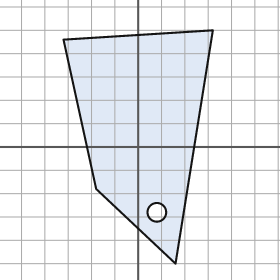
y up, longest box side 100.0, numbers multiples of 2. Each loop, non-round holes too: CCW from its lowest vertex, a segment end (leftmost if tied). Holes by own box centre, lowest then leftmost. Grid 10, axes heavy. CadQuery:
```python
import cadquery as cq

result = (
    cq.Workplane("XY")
    .moveTo(16.0, -50.0)
    .lineTo(32.0, 50.0)
    .lineTo(-32.0, 46.0)
    .lineTo(-18.0, -18.0)
    .close()
    .moveTo(8.0, -28.0)
    .circle(4.0)
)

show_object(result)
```